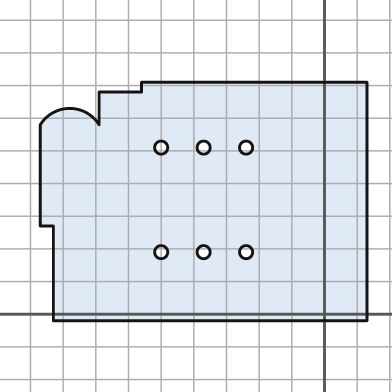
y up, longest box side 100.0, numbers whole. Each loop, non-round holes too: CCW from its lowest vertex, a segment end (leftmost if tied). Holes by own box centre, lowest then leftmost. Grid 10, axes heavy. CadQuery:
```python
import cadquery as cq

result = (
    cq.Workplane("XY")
    .moveTo(-83.0, -2.0)
    .lineTo(13.0, -2.0)
    .lineTo(13.0, 71.0)
    .lineTo(-56.0, 71.0)
    .lineTo(-56.0, 68.0)
    .lineTo(-69.0, 68.0)
    .lineTo(-69.0, 58.0)
    .threePointArc((-78.0, 63.0), (-87.0, 58.0))
    .lineTo(-87.0, 27.0)
    .lineTo(-83.0, 27.0)
    .close()
    .moveTo(-50.0, 19.0)
    .circle(2.0)
    .moveTo(-37.0, 19.0)
    .circle(2.0)
    .moveTo(-24.0, 19.0)
    .circle(2.0)
    .moveTo(-50.0, 51.0)
    .circle(2.0)
    .moveTo(-37.0, 51.0)
    .circle(2.0)
    .moveTo(-24.0, 51.0)
    .circle(2.0)
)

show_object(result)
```